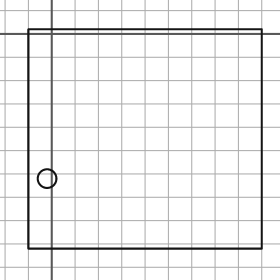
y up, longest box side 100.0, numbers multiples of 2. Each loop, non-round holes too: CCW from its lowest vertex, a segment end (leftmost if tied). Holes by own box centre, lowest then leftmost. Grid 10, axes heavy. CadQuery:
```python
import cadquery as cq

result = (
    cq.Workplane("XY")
    .moveTo(-10.0, -92.0)
    .lineTo(90.0, -92.0)
    .lineTo(90.0, 2.0)
    .lineTo(-10.0, 2.0)
    .close()
    .moveTo(-2.0, -62.0)
    .circle(4.0)
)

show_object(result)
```